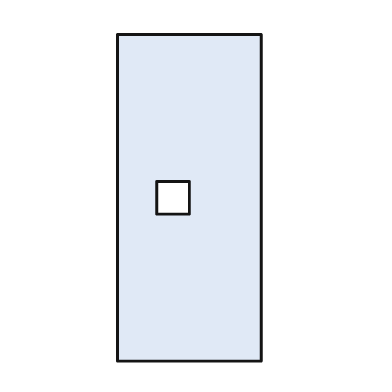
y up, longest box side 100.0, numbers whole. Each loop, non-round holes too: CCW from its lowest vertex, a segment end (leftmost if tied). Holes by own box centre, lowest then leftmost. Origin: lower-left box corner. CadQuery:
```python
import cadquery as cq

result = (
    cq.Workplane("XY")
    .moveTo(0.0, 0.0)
    .lineTo(44.0, 0.0)
    .lineTo(44.0, 100.0)
    .lineTo(0.0, 100.0)
    .close()
    .moveTo(12.0, 45.0)
    .lineTo(22.0, 45.0)
    .lineTo(22.0, 55.0)
    .lineTo(12.0, 55.0)
    .close()
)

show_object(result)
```